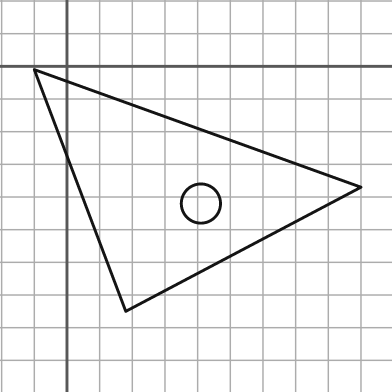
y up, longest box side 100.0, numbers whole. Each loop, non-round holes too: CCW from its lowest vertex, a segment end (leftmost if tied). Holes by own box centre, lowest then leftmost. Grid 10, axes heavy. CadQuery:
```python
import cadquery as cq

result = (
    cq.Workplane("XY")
    .moveTo(18.0, -75.0)
    .lineTo(90.0, -37.0)
    .lineTo(-10.0, -1.0)
    .close()
    .moveTo(41.0, -42.0)
    .circle(6.0)
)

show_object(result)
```